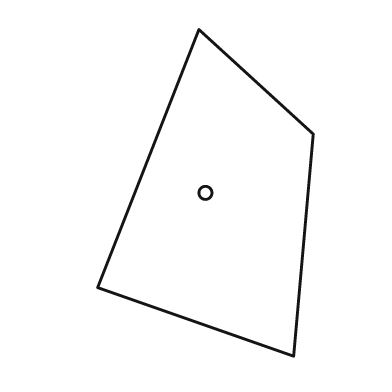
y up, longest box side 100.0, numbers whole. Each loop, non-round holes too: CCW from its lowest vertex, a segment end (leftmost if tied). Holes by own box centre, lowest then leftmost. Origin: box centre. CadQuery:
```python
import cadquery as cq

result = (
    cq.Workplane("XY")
    .moveTo(27.0, -50.0)
    .lineTo(33.0, 18.0)
    .lineTo(-2.0, 50.0)
    .lineTo(-33.0, -29.0)
    .close()
    .moveTo(0.0, 0.0)
    .circle(2.0)
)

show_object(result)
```